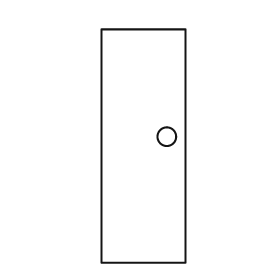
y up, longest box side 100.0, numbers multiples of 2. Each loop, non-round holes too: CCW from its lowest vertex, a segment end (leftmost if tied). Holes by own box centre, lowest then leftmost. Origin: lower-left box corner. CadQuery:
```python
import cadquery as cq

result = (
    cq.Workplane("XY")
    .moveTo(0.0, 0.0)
    .lineTo(36.0, 0.0)
    .lineTo(36.0, 100.0)
    .lineTo(0.0, 100.0)
    .close()
    .moveTo(28.0, 54.0)
    .circle(4.0)
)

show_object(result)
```